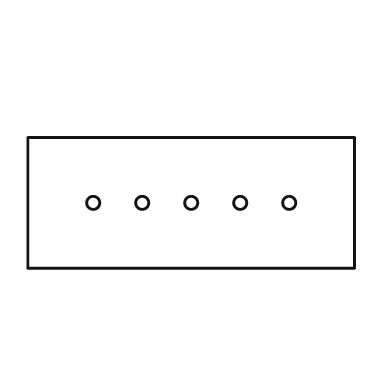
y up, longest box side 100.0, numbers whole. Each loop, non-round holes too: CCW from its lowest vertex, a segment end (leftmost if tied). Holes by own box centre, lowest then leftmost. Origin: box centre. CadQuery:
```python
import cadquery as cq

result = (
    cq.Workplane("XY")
    .moveTo(-50.0, -20.0)
    .lineTo(50.0, -20.0)
    .lineTo(50.0, 20.0)
    .lineTo(-50.0, 20.0)
    .close()
    .moveTo(-30.0, 0.0)
    .circle(2.0)
    .moveTo(-15.0, 0.0)
    .circle(2.0)
    .moveTo(0.0, 0.0)
    .circle(2.0)
    .moveTo(15.0, 0.0)
    .circle(2.0)
    .moveTo(30.0, 0.0)
    .circle(2.0)
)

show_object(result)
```